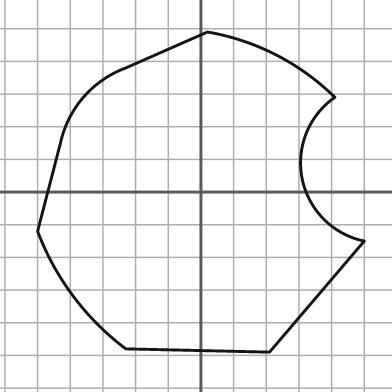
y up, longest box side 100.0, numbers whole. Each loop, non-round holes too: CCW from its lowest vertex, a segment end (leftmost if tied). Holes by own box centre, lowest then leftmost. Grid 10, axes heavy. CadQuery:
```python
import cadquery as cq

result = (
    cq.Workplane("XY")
    .moveTo(21.0, -49.0)
    .lineTo(50.0, -15.0)
    .threePointArc((31.0, 4.0), (41.0, 29.0))
    .threePointArc((23.0, 42.0), (2.0, 49.0))
    .lineTo(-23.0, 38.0)
    .threePointArc((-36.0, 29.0), (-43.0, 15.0))
    .lineTo(-50.0, -12.0)
    .threePointArc((-39.0, -32.0), (-23.0, -48.0))
    .close()
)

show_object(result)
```